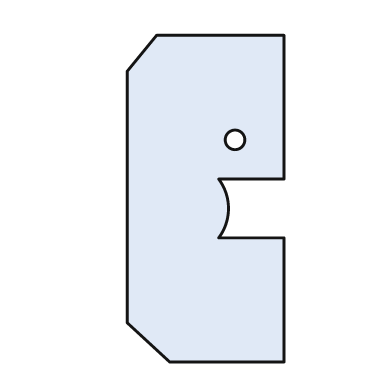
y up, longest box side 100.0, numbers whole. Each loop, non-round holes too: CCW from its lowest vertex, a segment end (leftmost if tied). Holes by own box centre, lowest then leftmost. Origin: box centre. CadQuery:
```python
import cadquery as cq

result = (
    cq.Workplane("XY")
    .moveTo(-11.0, -50.0)
    .lineTo(24.0, -50.0)
    .lineTo(24.0, -12.0)
    .lineTo(4.0, -12.0)
    .threePointArc((7.0, -3.0), (4.0, 6.0))
    .lineTo(24.0, 6.0)
    .lineTo(24.0, 50.0)
    .lineTo(-15.0, 50.0)
    .lineTo(-24.0, 39.0)
    .lineTo(-24.0, -38.0)
    .close()
    .moveTo(9.0, 18.0)
    .circle(3.0)
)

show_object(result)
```